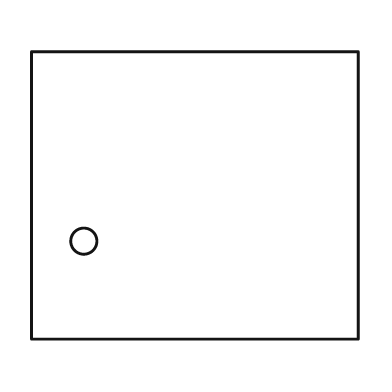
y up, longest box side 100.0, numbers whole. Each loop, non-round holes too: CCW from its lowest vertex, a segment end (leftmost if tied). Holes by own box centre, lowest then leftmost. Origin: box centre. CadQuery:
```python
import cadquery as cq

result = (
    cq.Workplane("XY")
    .moveTo(-50.0, -44.0)
    .lineTo(50.0, -44.0)
    .lineTo(50.0, 44.0)
    .lineTo(-50.0, 44.0)
    .close()
    .moveTo(-34.0, -14.0)
    .circle(4.0)
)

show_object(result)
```